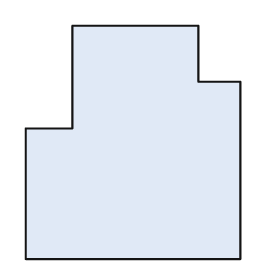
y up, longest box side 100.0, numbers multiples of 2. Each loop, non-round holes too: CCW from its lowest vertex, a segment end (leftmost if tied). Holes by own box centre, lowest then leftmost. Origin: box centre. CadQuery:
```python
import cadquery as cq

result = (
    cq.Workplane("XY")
    .moveTo(-46.0, -50.0)
    .lineTo(46.0, -50.0)
    .lineTo(46.0, 26.0)
    .lineTo(28.0, 26.0)
    .lineTo(28.0, 50.0)
    .lineTo(-26.0, 50.0)
    .lineTo(-26.0, 6.0)
    .lineTo(-46.0, 6.0)
    .close()
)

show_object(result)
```